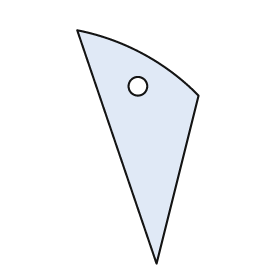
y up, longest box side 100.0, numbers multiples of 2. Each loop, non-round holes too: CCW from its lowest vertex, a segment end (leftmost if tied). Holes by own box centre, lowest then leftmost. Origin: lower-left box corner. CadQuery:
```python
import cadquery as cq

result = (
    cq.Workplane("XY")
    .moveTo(34.0, 0.0)
    .lineTo(52.0, 72.0)
    .threePointArc((28.0, 90.0), (0.0, 100.0))
    .close()
    .moveTo(26.0, 76.0)
    .circle(4.0)
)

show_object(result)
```